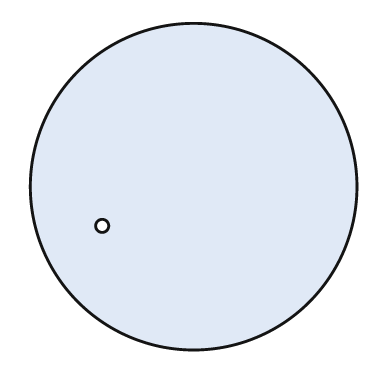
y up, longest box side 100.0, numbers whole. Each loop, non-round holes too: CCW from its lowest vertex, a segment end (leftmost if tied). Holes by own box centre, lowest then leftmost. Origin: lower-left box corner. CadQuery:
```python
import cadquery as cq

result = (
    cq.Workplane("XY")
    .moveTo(50.0, 50.0)
    .circle(50.0)
    .moveTo(22.0, 38.0)
    .circle(2.0)
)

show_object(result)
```